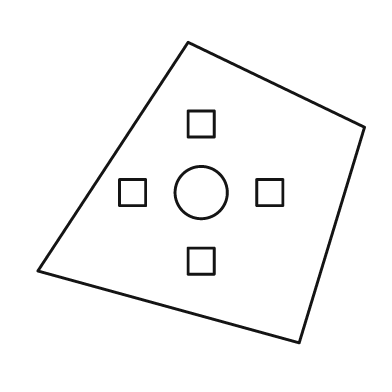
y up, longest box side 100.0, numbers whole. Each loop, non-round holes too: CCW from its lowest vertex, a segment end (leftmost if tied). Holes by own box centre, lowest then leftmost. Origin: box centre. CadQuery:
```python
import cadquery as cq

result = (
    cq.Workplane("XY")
    .moveTo(30.0, -46.0)
    .lineTo(50.0, 20.0)
    .lineTo(-4.0, 46.0)
    .lineTo(-50.0, -24.0)
    .close()
    .moveTo(-4.0, -25.0)
    .lineTo(4.0, -25.0)
    .lineTo(4.0, -17.0)
    .lineTo(-4.0, -17.0)
    .close()
    .moveTo(-25.0, -4.0)
    .lineTo(-17.0, -4.0)
    .lineTo(-17.0, 4.0)
    .lineTo(-25.0, 4.0)
    .close()
    .moveTo(0.0, 0.0)
    .circle(8.0)
    .moveTo(17.0, -4.0)
    .lineTo(25.0, -4.0)
    .lineTo(25.0, 4.0)
    .lineTo(17.0, 4.0)
    .close()
    .moveTo(-4.0, 17.0)
    .lineTo(4.0, 17.0)
    .lineTo(4.0, 25.0)
    .lineTo(-4.0, 25.0)
    .close()
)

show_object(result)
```